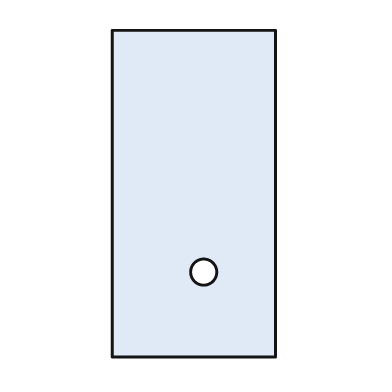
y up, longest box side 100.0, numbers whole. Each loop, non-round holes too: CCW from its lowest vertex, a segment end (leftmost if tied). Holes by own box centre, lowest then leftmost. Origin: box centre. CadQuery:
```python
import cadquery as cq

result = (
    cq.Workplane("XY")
    .moveTo(-25.0, -50.0)
    .lineTo(25.0, -50.0)
    .lineTo(25.0, 50.0)
    .lineTo(-25.0, 50.0)
    .close()
    .moveTo(3.0, -24.0)
    .circle(4.0)
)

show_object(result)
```